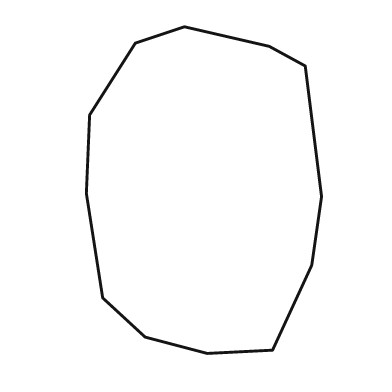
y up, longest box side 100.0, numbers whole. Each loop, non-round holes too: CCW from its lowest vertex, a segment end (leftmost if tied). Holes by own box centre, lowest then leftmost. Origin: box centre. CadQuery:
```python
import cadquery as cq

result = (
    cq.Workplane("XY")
    .moveTo(1.0, -50.0)
    .lineTo(21.0, -49.0)
    .lineTo(33.0, -23.0)
    .lineTo(36.0, -2.0)
    .lineTo(31.0, 38.0)
    .lineTo(20.0, 44.0)
    .lineTo(-6.0, 50.0)
    .lineTo(-21.0, 45.0)
    .lineTo(-35.0, 23.0)
    .lineTo(-36.0, -1.0)
    .lineTo(-31.0, -33.0)
    .lineTo(-18.0, -45.0)
    .close()
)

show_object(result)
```